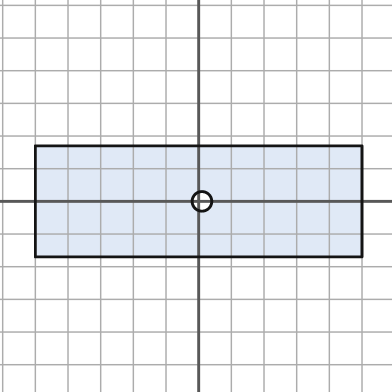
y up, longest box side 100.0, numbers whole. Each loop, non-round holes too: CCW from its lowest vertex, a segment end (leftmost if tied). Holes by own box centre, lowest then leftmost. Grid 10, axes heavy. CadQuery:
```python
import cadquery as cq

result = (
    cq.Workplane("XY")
    .moveTo(-50.0, -17.0)
    .lineTo(50.0, -17.0)
    .lineTo(50.0, 17.0)
    .lineTo(-50.0, 17.0)
    .close()
    .moveTo(1.0, 0.0)
    .circle(3.0)
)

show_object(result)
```